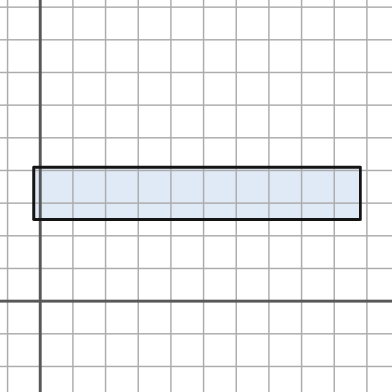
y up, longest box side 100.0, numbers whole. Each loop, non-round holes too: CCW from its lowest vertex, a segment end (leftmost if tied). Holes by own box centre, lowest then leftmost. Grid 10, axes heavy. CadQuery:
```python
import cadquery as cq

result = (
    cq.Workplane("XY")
    .moveTo(-2.0, 25.0)
    .lineTo(98.0, 25.0)
    .lineTo(98.0, 41.0)
    .lineTo(-2.0, 41.0)
    .close()
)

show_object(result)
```